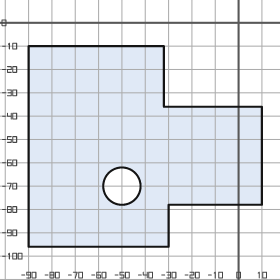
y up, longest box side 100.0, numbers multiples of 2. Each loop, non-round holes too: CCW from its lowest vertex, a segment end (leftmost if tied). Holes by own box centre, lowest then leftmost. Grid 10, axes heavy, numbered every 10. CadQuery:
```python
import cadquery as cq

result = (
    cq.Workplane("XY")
    .moveTo(-90.0, -96.0)
    .lineTo(-30.0, -96.0)
    .lineTo(-30.0, -78.0)
    .lineTo(10.0, -78.0)
    .lineTo(10.0, -36.0)
    .lineTo(-32.0, -36.0)
    .lineTo(-32.0, -10.0)
    .lineTo(-90.0, -10.0)
    .close()
    .moveTo(-50.0, -70.0)
    .circle(8.0)
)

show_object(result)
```